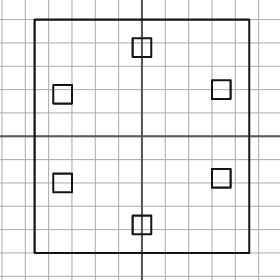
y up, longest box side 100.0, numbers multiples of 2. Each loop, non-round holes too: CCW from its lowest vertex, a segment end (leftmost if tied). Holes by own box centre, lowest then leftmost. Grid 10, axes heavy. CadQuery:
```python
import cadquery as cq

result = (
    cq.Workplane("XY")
    .moveTo(-46.0, -50.0)
    .lineTo(46.0, -50.0)
    .lineTo(46.0, 50.0)
    .lineTo(-46.0, 50.0)
    .close()
    .moveTo(-4.0, -42.0)
    .lineTo(4.0, -42.0)
    .lineTo(4.0, -34.0)
    .lineTo(-4.0, -34.0)
    .close()
    .moveTo(-38.0, -24.0)
    .lineTo(-30.0, -24.0)
    .lineTo(-30.0, -16.0)
    .lineTo(-38.0, -16.0)
    .close()
    .moveTo(30.0, -22.0)
    .lineTo(38.0, -22.0)
    .lineTo(38.0, -14.0)
    .lineTo(30.0, -14.0)
    .close()
    .moveTo(-38.0, 14.0)
    .lineTo(-30.0, 14.0)
    .lineTo(-30.0, 22.0)
    .lineTo(-38.0, 22.0)
    .close()
    .moveTo(30.0, 16.0)
    .lineTo(38.0, 16.0)
    .lineTo(38.0, 24.0)
    .lineTo(30.0, 24.0)
    .close()
    .moveTo(-4.0, 34.0)
    .lineTo(4.0, 34.0)
    .lineTo(4.0, 42.0)
    .lineTo(-4.0, 42.0)
    .close()
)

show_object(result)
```